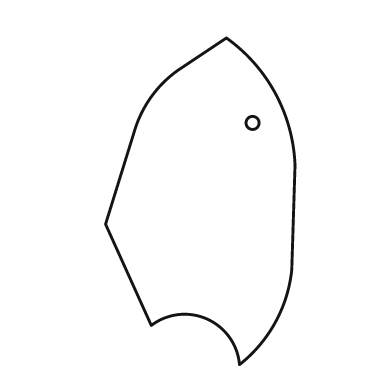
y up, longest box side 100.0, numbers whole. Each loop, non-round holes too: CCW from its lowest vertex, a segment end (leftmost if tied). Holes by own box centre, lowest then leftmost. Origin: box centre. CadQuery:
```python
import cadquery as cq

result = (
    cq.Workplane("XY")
    .moveTo(12.0, -50.0)
    .threePointArc((23.0, -37.0), (28.0, -21.0))
    .lineTo(29.0, 11.0)
    .threePointArc((23.0, 33.0), (8.0, 50.0))
    .lineTo(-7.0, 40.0)
    .threePointArc((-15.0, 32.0), (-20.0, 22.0))
    .lineTo(-29.0, -7.0)
    .lineTo(-15.0, -38.0)
    .threePointArc((2.0, -36.0), (12.0, -50.0))
    .close()
    .moveTo(16.0, 24.0)
    .circle(2.0)
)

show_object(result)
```